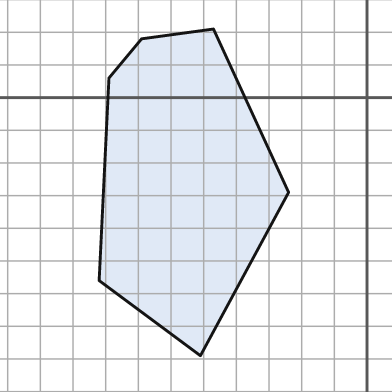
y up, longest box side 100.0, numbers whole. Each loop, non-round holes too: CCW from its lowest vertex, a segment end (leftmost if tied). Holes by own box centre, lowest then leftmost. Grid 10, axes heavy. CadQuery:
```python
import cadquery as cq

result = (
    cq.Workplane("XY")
    .moveTo(-51.0, -79.0)
    .lineTo(-24.0, -29.0)
    .lineTo(-47.0, 21.0)
    .lineTo(-69.0, 18.0)
    .lineTo(-79.0, 6.0)
    .lineTo(-82.0, -56.0)
    .close()
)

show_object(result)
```